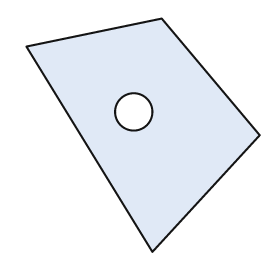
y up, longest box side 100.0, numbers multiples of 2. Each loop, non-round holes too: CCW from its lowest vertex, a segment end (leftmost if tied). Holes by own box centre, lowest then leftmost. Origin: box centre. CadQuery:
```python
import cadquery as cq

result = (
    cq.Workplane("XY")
    .moveTo(4.0, -50.0)
    .lineTo(50.0, 0.0)
    .lineTo(8.0, 50.0)
    .lineTo(-50.0, 38.0)
    .close()
    .moveTo(-4.0, 10.0)
    .circle(8.0)
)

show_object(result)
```